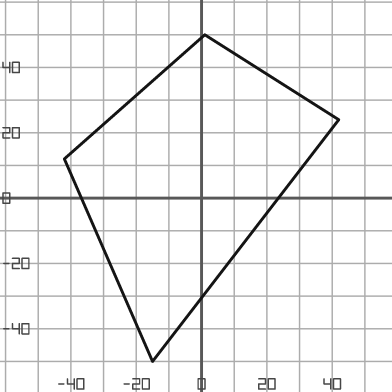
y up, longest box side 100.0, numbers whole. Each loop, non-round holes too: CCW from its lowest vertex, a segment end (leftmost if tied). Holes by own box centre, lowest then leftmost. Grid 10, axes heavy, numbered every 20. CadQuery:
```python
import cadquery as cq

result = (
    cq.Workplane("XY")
    .moveTo(-15.0, -50.0)
    .lineTo(42.0, 24.0)
    .lineTo(1.0, 50.0)
    .lineTo(-42.0, 12.0)
    .close()
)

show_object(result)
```